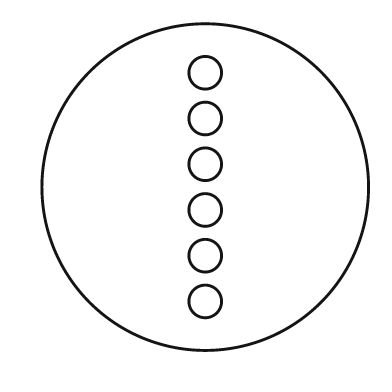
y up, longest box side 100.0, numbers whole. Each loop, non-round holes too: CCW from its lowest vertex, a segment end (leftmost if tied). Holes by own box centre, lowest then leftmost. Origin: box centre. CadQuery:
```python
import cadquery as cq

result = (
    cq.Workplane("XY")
    .moveTo(0.0, 0.0)
    .circle(50.0)
    .moveTo(0.0, -35.0)
    .circle(5.0)
    .moveTo(0.0, -21.0)
    .circle(5.0)
    .moveTo(0.0, -7.0)
    .circle(5.0)
    .moveTo(0.0, 7.0)
    .circle(5.0)
    .moveTo(0.0, 21.0)
    .circle(5.0)
    .moveTo(0.0, 35.0)
    .circle(5.0)
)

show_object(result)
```